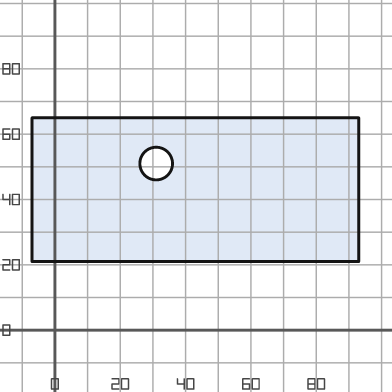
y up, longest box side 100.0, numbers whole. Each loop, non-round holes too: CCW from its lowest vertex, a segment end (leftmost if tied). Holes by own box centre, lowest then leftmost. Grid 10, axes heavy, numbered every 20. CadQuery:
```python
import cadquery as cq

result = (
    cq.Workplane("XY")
    .moveTo(-7.0, 21.0)
    .lineTo(93.0, 21.0)
    .lineTo(93.0, 65.0)
    .lineTo(-7.0, 65.0)
    .close()
    .moveTo(31.0, 51.0)
    .circle(5.0)
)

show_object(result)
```